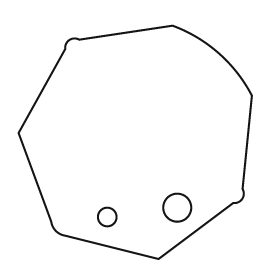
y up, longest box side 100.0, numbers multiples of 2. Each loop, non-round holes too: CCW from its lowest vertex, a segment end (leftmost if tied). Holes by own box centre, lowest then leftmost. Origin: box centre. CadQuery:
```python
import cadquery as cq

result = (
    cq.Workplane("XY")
    .moveTo(10.0, -50.0)
    .lineTo(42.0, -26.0)
    .threePointArc((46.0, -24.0), (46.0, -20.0))
    .lineTo(50.0, 20.0)
    .threePointArc((36.0, 38.0), (16.0, 50.0))
    .lineTo(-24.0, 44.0)
    .threePointArc((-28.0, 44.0), (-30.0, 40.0))
    .lineTo(-50.0, 4.0)
    .lineTo(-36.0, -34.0)
    .threePointArc((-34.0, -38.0), (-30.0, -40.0))
    .close()
    .moveTo(-12.0, -32.0)
    .circle(4.0)
    .moveTo(18.0, -28.0)
    .circle(6.0)
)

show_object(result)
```